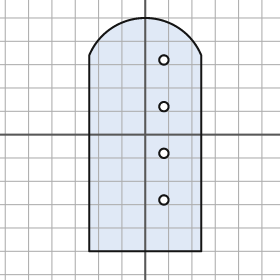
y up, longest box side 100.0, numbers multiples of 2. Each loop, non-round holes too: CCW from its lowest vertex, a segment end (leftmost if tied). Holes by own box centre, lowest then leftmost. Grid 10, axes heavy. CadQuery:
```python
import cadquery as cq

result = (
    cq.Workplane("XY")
    .moveTo(-24.0, -50.0)
    .lineTo(24.0, -50.0)
    .lineTo(24.0, 34.0)
    .threePointArc((0.0, 50.0), (-24.0, 34.0))
    .close()
    .moveTo(8.0, -28.0)
    .circle(2.0)
    .moveTo(8.0, -8.0)
    .circle(2.0)
    .moveTo(8.0, 12.0)
    .circle(2.0)
    .moveTo(8.0, 32.0)
    .circle(2.0)
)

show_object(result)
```